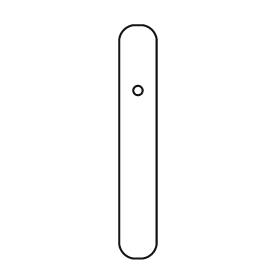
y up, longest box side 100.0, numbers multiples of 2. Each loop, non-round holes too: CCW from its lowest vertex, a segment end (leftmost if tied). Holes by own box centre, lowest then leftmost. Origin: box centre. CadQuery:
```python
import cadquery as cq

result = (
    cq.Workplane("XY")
    .moveTo(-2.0, -50.0)
    .lineTo(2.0, -50.0)
    .threePointArc((6.0, -48.0), (8.0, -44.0))
    .lineTo(8.0, 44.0)
    .threePointArc((6.0, 48.0), (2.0, 50.0))
    .lineTo(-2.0, 50.0)
    .threePointArc((-6.0, 48.0), (-8.0, 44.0))
    .lineTo(-8.0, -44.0)
    .threePointArc((-6.0, -48.0), (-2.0, -50.0))
    .close()
    .moveTo(0.0, 22.0)
    .circle(2.0)
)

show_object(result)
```